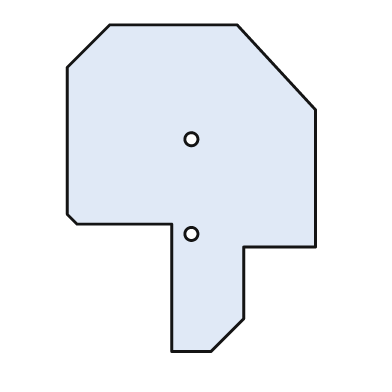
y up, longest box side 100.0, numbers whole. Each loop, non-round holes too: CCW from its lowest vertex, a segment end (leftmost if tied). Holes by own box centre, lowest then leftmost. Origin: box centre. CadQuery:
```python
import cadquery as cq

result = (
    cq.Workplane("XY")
    .moveTo(-6.0, -50.0)
    .lineTo(6.0, -50.0)
    .lineTo(16.0, -40.0)
    .lineTo(16.0, -18.0)
    .lineTo(38.0, -18.0)
    .lineTo(38.0, 24.0)
    .lineTo(14.0, 50.0)
    .lineTo(-25.0, 50.0)
    .lineTo(-38.0, 37.0)
    .lineTo(-38.0, -8.0)
    .lineTo(-35.0, -11.0)
    .lineTo(-6.0, -11.0)
    .close()
    .moveTo(0.0, -14.0)
    .circle(2.0)
    .moveTo(0.0, 15.0)
    .circle(2.0)
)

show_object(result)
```